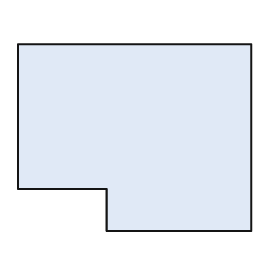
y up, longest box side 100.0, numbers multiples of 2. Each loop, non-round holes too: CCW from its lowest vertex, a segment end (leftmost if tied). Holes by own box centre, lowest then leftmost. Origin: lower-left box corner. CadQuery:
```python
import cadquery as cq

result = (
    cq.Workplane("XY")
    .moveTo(38.0, 0.0)
    .lineTo(100.0, 0.0)
    .lineTo(100.0, 80.0)
    .lineTo(0.0, 80.0)
    .lineTo(0.0, 18.0)
    .lineTo(38.0, 18.0)
    .close()
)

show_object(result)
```